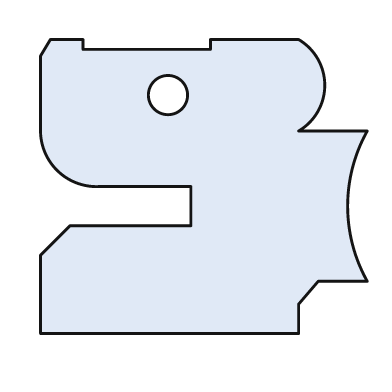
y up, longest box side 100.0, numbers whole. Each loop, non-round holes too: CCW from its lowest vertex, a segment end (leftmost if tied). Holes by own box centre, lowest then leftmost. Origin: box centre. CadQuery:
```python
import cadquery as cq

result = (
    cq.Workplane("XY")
    .moveTo(-50.0, -45.0)
    .lineTo(29.0, -45.0)
    .lineTo(29.0, -36.0)
    .lineTo(35.0, -29.0)
    .lineTo(50.0, -29.0)
    .threePointArc((44.0, -6.0), (50.0, 17.0))
    .lineTo(29.0, 17.0)
    .threePointArc((37.0, 31.0), (29.0, 45.0))
    .lineTo(2.0, 45.0)
    .lineTo(2.0, 42.0)
    .lineTo(-37.0, 42.0)
    .lineTo(-37.0, 45.0)
    .lineTo(-47.0, 45.0)
    .lineTo(-50.0, 40.0)
    .lineTo(-50.0, 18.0)
    .threePointArc((-45.0, 5.0), (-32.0, 0.0))
    .lineTo(-4.0, 0.0)
    .lineTo(-4.0, -12.0)
    .lineTo(-41.0, -12.0)
    .lineTo(-50.0, -21.0)
    .close()
    .moveTo(-11.0, 28.0)
    .circle(6.0)
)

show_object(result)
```